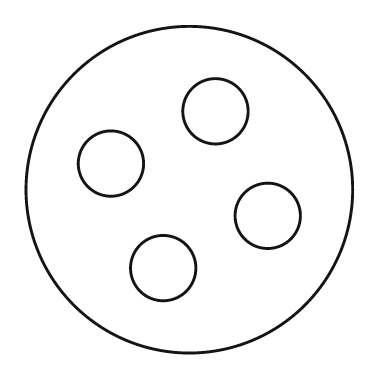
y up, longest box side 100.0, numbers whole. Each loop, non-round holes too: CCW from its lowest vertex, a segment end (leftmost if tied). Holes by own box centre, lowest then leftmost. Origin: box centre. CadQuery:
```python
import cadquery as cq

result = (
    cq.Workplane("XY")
    .moveTo(0.0, 0.0)
    .circle(50.0)
    .moveTo(-8.0, -24.0)
    .circle(10.0)
    .moveTo(24.0, -8.0)
    .circle(10.0)
    .moveTo(-24.0, 8.0)
    .circle(10.0)
    .moveTo(8.0, 24.0)
    .circle(10.0)
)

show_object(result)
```